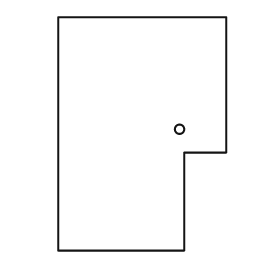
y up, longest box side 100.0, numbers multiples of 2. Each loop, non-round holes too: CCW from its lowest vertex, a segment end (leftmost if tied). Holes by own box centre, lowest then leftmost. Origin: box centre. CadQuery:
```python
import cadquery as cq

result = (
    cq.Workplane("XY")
    .moveTo(-36.0, -50.0)
    .lineTo(18.0, -50.0)
    .lineTo(18.0, -8.0)
    .lineTo(36.0, -8.0)
    .lineTo(36.0, 50.0)
    .lineTo(-36.0, 50.0)
    .close()
    .moveTo(16.0, 2.0)
    .circle(2.0)
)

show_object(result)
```